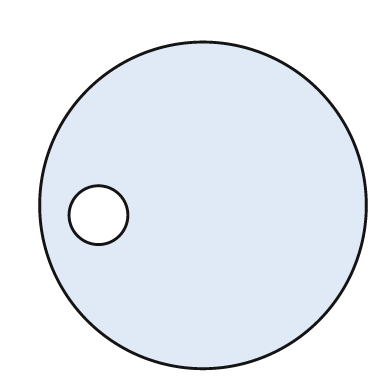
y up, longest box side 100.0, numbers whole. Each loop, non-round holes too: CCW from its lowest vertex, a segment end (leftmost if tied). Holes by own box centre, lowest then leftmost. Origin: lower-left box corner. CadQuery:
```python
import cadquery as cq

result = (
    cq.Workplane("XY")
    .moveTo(50.0, 50.0)
    .circle(50.0)
    .moveTo(18.0, 47.0)
    .circle(9.0)
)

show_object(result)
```